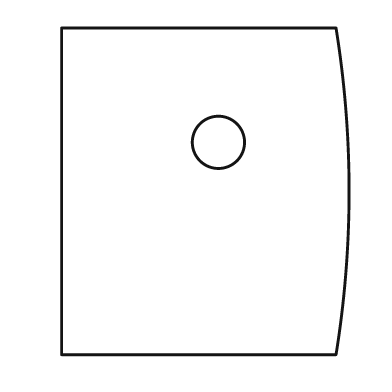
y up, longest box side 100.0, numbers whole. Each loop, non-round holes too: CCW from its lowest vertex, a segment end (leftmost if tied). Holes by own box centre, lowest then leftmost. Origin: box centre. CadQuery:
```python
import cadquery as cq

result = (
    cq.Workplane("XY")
    .moveTo(-44.0, -50.0)
    .lineTo(40.0, -50.0)
    .threePointArc((44.0, 0.0), (40.0, 50.0))
    .lineTo(-44.0, 50.0)
    .close()
    .moveTo(4.0, 15.0)
    .circle(8.0)
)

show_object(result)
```